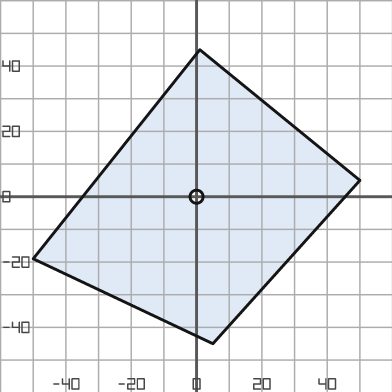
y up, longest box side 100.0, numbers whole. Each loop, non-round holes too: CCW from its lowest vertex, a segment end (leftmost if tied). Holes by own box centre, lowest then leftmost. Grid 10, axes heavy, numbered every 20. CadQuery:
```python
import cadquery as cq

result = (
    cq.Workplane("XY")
    .moveTo(5.0, -45.0)
    .lineTo(50.0, 5.0)
    .lineTo(1.0, 45.0)
    .lineTo(-50.0, -19.0)
    .close()
    .moveTo(0.0, 0.0)
    .circle(2.0)
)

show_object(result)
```